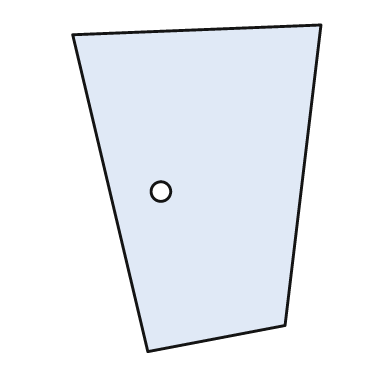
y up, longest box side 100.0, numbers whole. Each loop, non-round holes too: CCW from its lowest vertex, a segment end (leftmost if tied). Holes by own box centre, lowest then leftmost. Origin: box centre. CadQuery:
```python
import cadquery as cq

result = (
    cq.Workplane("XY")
    .moveTo(-15.0, -50.0)
    .lineTo(27.0, -42.0)
    .lineTo(38.0, 50.0)
    .lineTo(-38.0, 47.0)
    .close()
    .moveTo(-11.0, -1.0)
    .circle(3.0)
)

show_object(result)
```